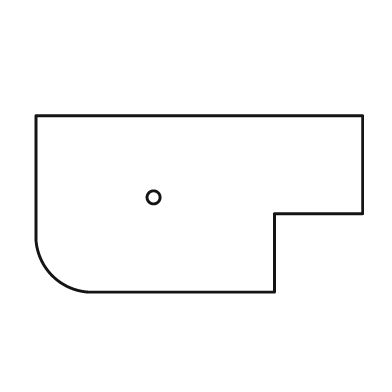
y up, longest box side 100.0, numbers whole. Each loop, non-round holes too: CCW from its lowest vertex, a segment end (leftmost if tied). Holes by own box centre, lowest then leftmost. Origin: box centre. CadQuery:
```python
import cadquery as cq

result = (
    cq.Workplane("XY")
    .moveTo(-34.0, -27.0)
    .lineTo(23.0, -27.0)
    .lineTo(23.0, -3.0)
    .lineTo(50.0, -3.0)
    .lineTo(50.0, 27.0)
    .lineTo(-50.0, 27.0)
    .lineTo(-50.0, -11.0)
    .threePointArc((-45.0, -22.0), (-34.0, -27.0))
    .close()
    .moveTo(-14.0, 2.0)
    .circle(2.0)
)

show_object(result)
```